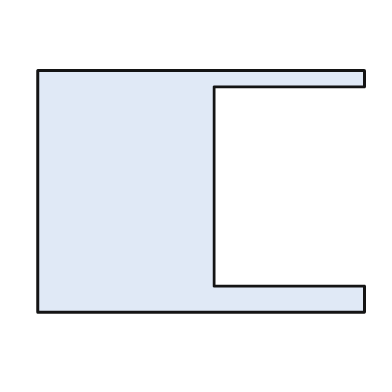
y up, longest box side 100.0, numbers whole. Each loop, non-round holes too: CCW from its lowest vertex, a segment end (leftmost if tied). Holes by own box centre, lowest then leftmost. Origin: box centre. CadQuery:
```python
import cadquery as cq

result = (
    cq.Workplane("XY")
    .moveTo(-50.0, -37.0)
    .lineTo(50.0, -37.0)
    .lineTo(50.0, -29.0)
    .lineTo(4.0, -29.0)
    .lineTo(4.0, 32.0)
    .lineTo(50.0, 32.0)
    .lineTo(50.0, 37.0)
    .lineTo(-50.0, 37.0)
    .close()
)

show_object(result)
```